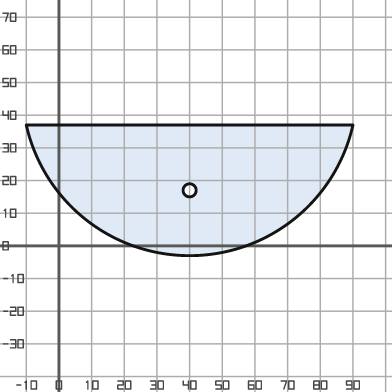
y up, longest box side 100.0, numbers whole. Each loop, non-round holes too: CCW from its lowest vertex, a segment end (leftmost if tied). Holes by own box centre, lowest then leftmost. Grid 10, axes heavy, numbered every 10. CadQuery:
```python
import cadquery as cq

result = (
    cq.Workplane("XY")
    .moveTo(-10.0, 37.0)
    .threePointArc((40.0, -3.0), (90.0, 37.0))
    .close()
    .moveTo(40.0, 17.0)
    .circle(2.0)
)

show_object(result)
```